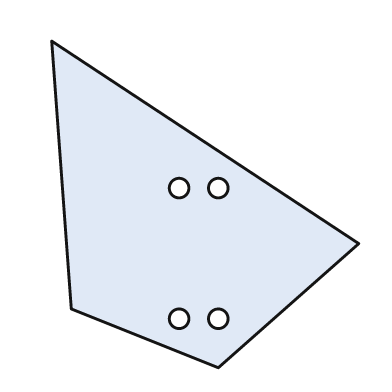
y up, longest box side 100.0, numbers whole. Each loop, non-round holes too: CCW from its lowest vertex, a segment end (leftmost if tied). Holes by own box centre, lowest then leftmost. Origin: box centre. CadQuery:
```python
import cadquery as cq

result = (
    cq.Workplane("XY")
    .moveTo(4.0, -50.0)
    .lineTo(47.0, -12.0)
    .lineTo(-47.0, 50.0)
    .lineTo(-41.0, -32.0)
    .close()
    .moveTo(-8.0, -35.0)
    .circle(3.0)
    .moveTo(4.0, -35.0)
    .circle(3.0)
    .moveTo(-8.0, 5.0)
    .circle(3.0)
    .moveTo(4.0, 5.0)
    .circle(3.0)
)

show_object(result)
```